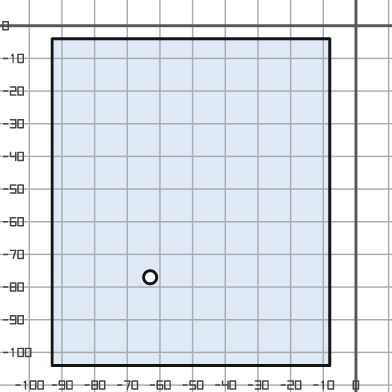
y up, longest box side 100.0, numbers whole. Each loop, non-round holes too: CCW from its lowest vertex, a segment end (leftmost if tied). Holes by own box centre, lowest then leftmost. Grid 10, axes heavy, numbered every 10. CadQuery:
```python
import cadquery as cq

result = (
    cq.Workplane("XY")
    .moveTo(-93.0, -104.0)
    .lineTo(-8.0, -104.0)
    .lineTo(-8.0, -4.0)
    .lineTo(-93.0, -4.0)
    .close()
    .moveTo(-63.0, -77.0)
    .circle(2.0)
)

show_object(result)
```